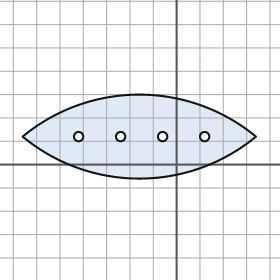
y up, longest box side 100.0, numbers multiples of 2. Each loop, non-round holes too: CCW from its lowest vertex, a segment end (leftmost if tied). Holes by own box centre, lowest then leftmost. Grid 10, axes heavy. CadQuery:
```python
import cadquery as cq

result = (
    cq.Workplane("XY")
    .moveTo(-66.0, 12.0)
    .threePointArc((-16.0, -6.0), (34.0, 12.0))
    .threePointArc((-16.0, 30.0), (-66.0, 12.0))
    .close()
    .moveTo(-42.0, 12.0)
    .circle(2.0)
    .moveTo(-24.0, 12.0)
    .circle(2.0)
    .moveTo(-6.0, 12.0)
    .circle(2.0)
    .moveTo(12.0, 12.0)
    .circle(2.0)
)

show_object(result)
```